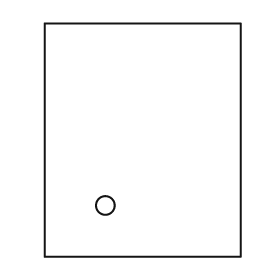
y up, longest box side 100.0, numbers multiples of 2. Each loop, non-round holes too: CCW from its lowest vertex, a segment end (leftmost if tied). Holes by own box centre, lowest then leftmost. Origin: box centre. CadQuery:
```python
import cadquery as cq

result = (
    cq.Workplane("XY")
    .moveTo(-42.0, -50.0)
    .lineTo(42.0, -50.0)
    .lineTo(42.0, 50.0)
    .lineTo(-42.0, 50.0)
    .close()
    .moveTo(-16.0, -28.0)
    .circle(4.0)
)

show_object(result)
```